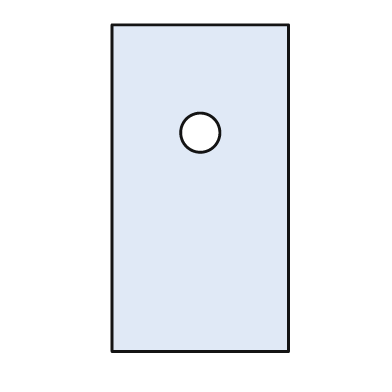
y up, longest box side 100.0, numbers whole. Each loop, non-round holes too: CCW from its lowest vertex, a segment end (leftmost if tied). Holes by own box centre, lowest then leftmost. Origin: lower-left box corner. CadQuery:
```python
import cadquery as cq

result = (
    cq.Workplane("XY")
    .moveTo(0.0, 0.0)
    .lineTo(54.0, 0.0)
    .lineTo(54.0, 100.0)
    .lineTo(0.0, 100.0)
    .close()
    .moveTo(27.0, 67.0)
    .circle(6.0)
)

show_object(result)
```